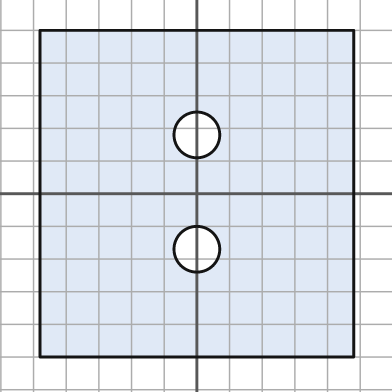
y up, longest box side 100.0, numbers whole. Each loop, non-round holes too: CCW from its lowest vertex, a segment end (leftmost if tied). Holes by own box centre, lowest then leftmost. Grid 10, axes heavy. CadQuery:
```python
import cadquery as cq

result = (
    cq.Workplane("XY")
    .moveTo(-48.0, -50.0)
    .lineTo(48.0, -50.0)
    .lineTo(48.0, 50.0)
    .lineTo(-48.0, 50.0)
    .close()
    .moveTo(0.0, -17.0)
    .circle(7.0)
    .moveTo(0.0, 18.0)
    .circle(7.0)
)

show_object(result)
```